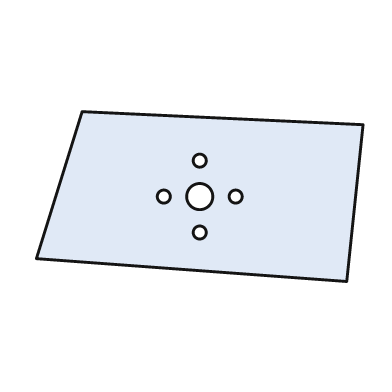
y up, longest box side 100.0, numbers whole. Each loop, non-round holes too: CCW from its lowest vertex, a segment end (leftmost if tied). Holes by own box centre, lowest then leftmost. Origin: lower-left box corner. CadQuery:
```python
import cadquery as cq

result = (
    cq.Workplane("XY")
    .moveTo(95.0, 0.0)
    .lineTo(100.0, 48.0)
    .lineTo(14.0, 52.0)
    .lineTo(0.0, 7.0)
    .close()
    .moveTo(50.0, 15.0)
    .circle(2.0)
    .moveTo(39.0, 26.0)
    .circle(2.0)
    .moveTo(50.0, 26.0)
    .circle(4.0)
    .moveTo(61.0, 26.0)
    .circle(2.0)
    .moveTo(50.0, 37.0)
    .circle(2.0)
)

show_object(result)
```